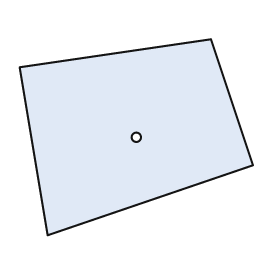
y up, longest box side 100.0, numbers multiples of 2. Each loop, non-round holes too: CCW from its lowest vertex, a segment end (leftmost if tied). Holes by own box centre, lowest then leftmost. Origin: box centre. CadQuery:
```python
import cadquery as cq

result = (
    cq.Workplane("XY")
    .moveTo(-38.0, -42.0)
    .lineTo(50.0, -12.0)
    .lineTo(32.0, 42.0)
    .lineTo(-50.0, 30.0)
    .close()
    .moveTo(0.0, 0.0)
    .circle(2.0)
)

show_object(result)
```